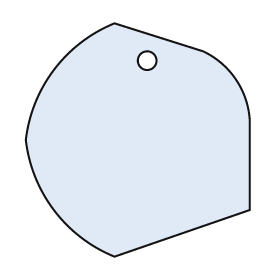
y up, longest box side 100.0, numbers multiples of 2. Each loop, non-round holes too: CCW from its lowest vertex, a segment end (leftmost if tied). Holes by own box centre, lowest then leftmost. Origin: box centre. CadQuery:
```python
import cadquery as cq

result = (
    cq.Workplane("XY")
    .moveTo(-10.0, -50.0)
    .lineTo(48.0, -30.0)
    .lineTo(48.0, 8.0)
    .threePointArc((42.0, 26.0), (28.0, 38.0))
    .lineTo(-10.0, 50.0)
    .threePointArc((-36.0, 30.0), (-48.0, 0.0))
    .threePointArc((-36.0, -30.0), (-10.0, -50.0))
    .close()
    .moveTo(4.0, 34.0)
    .circle(4.0)
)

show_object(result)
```